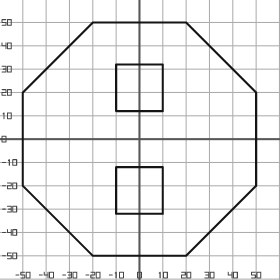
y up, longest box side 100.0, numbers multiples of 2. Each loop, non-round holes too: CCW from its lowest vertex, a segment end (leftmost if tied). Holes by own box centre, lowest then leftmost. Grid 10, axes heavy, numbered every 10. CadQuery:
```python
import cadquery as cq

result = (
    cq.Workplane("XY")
    .moveTo(-20.0, -50.0)
    .lineTo(20.0, -50.0)
    .lineTo(50.0, -20.0)
    .lineTo(50.0, 20.0)
    .lineTo(20.0, 50.0)
    .lineTo(-20.0, 50.0)
    .lineTo(-50.0, 20.0)
    .lineTo(-50.0, -20.0)
    .close()
    .moveTo(-10.0, -32.0)
    .lineTo(10.0, -32.0)
    .lineTo(10.0, -12.0)
    .lineTo(-10.0, -12.0)
    .close()
    .moveTo(-10.0, 12.0)
    .lineTo(10.0, 12.0)
    .lineTo(10.0, 32.0)
    .lineTo(-10.0, 32.0)
    .close()
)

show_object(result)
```